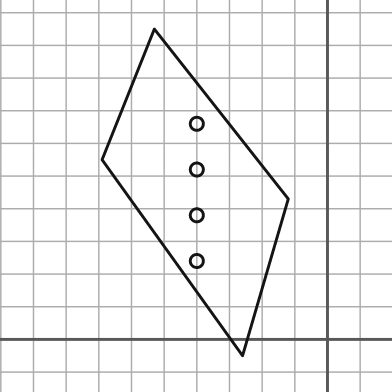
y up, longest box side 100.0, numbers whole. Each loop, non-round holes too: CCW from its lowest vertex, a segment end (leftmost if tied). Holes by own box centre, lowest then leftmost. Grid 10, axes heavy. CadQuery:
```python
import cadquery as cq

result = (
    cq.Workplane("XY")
    .moveTo(-26.0, -5.0)
    .lineTo(-12.0, 43.0)
    .lineTo(-53.0, 95.0)
    .lineTo(-69.0, 55.0)
    .close()
    .moveTo(-40.0, 24.0)
    .circle(2.0)
    .moveTo(-40.0, 38.0)
    .circle(2.0)
    .moveTo(-40.0, 52.0)
    .circle(2.0)
    .moveTo(-40.0, 66.0)
    .circle(2.0)
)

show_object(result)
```